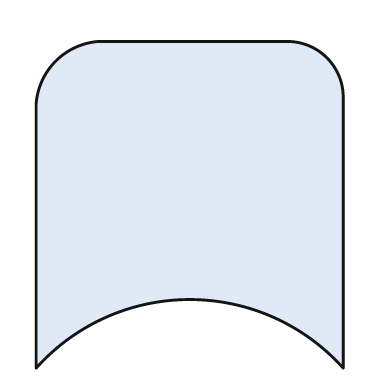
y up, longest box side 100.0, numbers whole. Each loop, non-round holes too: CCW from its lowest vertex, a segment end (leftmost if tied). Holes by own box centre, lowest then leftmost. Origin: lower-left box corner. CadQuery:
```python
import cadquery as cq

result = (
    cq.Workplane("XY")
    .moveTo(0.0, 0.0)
    .threePointArc((47.0, 21.0), (94.0, 0.0))
    .lineTo(94.0, 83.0)
    .threePointArc((89.0, 95.0), (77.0, 100.0))
    .lineTo(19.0, 100.0)
    .threePointArc((6.0, 94.0), (0.0, 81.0))
    .close()
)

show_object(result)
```